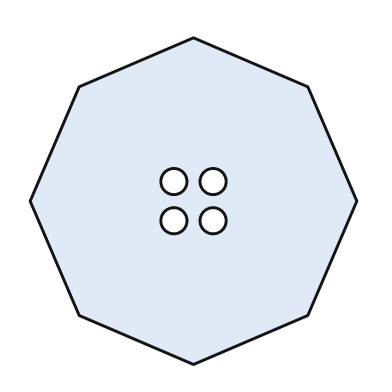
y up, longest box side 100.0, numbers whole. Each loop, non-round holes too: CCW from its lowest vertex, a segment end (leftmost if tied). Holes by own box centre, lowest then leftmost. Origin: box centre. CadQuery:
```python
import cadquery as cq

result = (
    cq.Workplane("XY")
    .moveTo(0.0, -50.0)
    .lineTo(35.0, -35.0)
    .lineTo(50.0, 0.0)
    .lineTo(35.0, 35.0)
    .lineTo(0.0, 50.0)
    .lineTo(-35.0, 35.0)
    .lineTo(-50.0, 0.0)
    .lineTo(-35.0, -35.0)
    .close()
    .moveTo(-6.0, -6.0)
    .circle(4.0)
    .moveTo(6.0, -6.0)
    .circle(4.0)
    .moveTo(-6.0, 6.0)
    .circle(4.0)
    .moveTo(6.0, 6.0)
    .circle(4.0)
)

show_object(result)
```